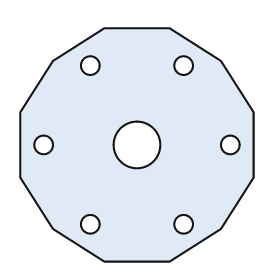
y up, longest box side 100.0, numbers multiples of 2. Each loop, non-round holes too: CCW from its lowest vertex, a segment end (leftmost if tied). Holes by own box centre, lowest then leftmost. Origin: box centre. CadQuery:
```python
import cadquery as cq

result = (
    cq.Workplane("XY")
    .moveTo(-14.0, -50.0)
    .lineTo(14.0, -50.0)
    .lineTo(36.0, -36.0)
    .lineTo(50.0, -14.0)
    .lineTo(50.0, 14.0)
    .lineTo(36.0, 36.0)
    .lineTo(14.0, 50.0)
    .lineTo(-14.0, 50.0)
    .lineTo(-36.0, 36.0)
    .lineTo(-50.0, 14.0)
    .lineTo(-50.0, -14.0)
    .lineTo(-36.0, -36.0)
    .close()
    .moveTo(-20.0, -34.0)
    .circle(4.0)
    .moveTo(20.0, -34.0)
    .circle(4.0)
    .moveTo(-40.0, 0.0)
    .circle(4.0)
    .moveTo(0.0, 0.0)
    .circle(10.0)
    .moveTo(40.0, 0.0)
    .circle(4.0)
    .moveTo(-20.0, 34.0)
    .circle(4.0)
    .moveTo(20.0, 34.0)
    .circle(4.0)
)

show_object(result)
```